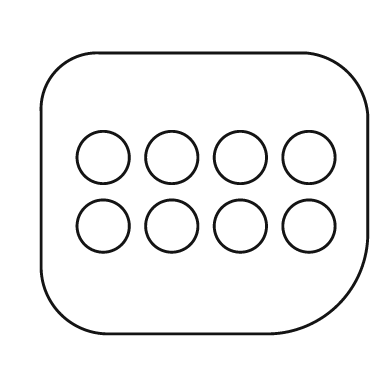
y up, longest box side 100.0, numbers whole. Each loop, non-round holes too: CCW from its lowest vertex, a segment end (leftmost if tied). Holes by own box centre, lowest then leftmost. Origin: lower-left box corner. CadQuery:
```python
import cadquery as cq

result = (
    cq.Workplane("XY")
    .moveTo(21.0, 0.0)
    .lineTo(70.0, 0.0)
    .threePointArc((91.0, 9.0), (100.0, 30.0))
    .lineTo(100.0, 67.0)
    .threePointArc((94.0, 80.0), (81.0, 86.0))
    .lineTo(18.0, 86.0)
    .threePointArc((5.0, 81.0), (0.0, 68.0))
    .lineTo(0.0, 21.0)
    .threePointArc((6.0, 6.0), (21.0, 0.0))
    .close()
    .moveTo(19.0, 33.0)
    .circle(8.0)
    .moveTo(40.0, 33.0)
    .circle(8.0)
    .moveTo(61.0, 33.0)
    .circle(8.0)
    .moveTo(82.0, 33.0)
    .circle(8.0)
    .moveTo(19.0, 54.0)
    .circle(8.0)
    .moveTo(40.0, 54.0)
    .circle(8.0)
    .moveTo(61.0, 54.0)
    .circle(8.0)
    .moveTo(82.0, 54.0)
    .circle(8.0)
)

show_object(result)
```